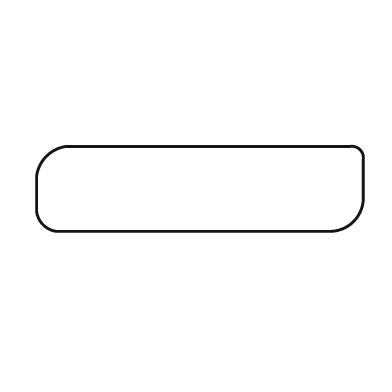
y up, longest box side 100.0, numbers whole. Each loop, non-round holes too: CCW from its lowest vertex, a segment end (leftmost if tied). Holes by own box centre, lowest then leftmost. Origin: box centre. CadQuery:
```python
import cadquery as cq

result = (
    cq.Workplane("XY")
    .moveTo(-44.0, -13.0)
    .lineTo(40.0, -13.0)
    .threePointArc((47.0, -10.0), (50.0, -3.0))
    .lineTo(50.0, 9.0)
    .threePointArc((49.0, 12.0), (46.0, 13.0))
    .lineTo(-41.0, 13.0)
    .threePointArc((-47.0, 10.0), (-50.0, 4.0))
    .lineTo(-50.0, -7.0)
    .threePointArc((-48.0, -11.0), (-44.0, -13.0))
    .close()
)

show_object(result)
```